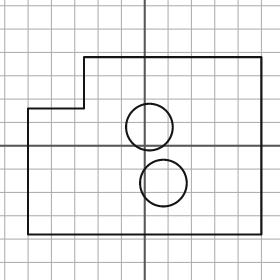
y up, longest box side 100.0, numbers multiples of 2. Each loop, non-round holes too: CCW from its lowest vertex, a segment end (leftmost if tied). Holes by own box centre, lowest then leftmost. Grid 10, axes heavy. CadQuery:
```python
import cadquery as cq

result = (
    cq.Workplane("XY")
    .moveTo(-50.0, -38.0)
    .lineTo(50.0, -38.0)
    .lineTo(50.0, 38.0)
    .lineTo(-26.0, 38.0)
    .lineTo(-26.0, 16.0)
    .lineTo(-50.0, 16.0)
    .close()
    .moveTo(8.0, -16.0)
    .circle(10.0)
    .moveTo(2.0, 8.0)
    .circle(10.0)
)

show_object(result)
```